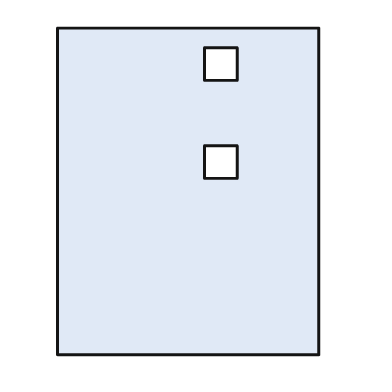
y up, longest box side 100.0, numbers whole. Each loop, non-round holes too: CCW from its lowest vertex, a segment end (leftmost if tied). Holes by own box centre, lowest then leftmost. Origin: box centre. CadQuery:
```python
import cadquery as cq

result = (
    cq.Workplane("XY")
    .moveTo(-40.0, -50.0)
    .lineTo(40.0, -50.0)
    .lineTo(40.0, 50.0)
    .lineTo(-40.0, 50.0)
    .close()
    .moveTo(5.0, 4.0)
    .lineTo(15.0, 4.0)
    .lineTo(15.0, 14.0)
    .lineTo(5.0, 14.0)
    .close()
    .moveTo(5.0, 34.0)
    .lineTo(15.0, 34.0)
    .lineTo(15.0, 44.0)
    .lineTo(5.0, 44.0)
    .close()
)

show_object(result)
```